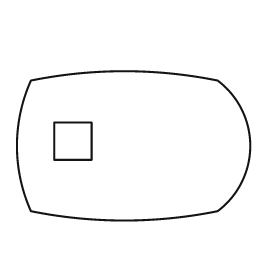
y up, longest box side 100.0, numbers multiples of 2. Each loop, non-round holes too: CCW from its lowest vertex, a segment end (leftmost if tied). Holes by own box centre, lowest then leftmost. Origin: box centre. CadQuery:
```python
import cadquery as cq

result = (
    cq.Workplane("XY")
    .moveTo(-44.0, -28.0)
    .threePointArc((-4.0, -32.0), (36.0, -28.0))
    .threePointArc((50.0, 0.0), (36.0, 28.0))
    .threePointArc((-4.0, 32.0), (-44.0, 28.0))
    .threePointArc((-50.0, 0.0), (-44.0, -28.0))
    .close()
    .moveTo(-34.0, -6.0)
    .lineTo(-18.0, -6.0)
    .lineTo(-18.0, 10.0)
    .lineTo(-34.0, 10.0)
    .close()
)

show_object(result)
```